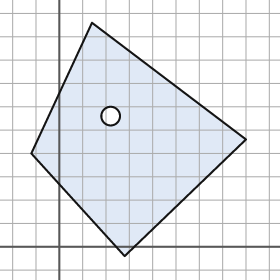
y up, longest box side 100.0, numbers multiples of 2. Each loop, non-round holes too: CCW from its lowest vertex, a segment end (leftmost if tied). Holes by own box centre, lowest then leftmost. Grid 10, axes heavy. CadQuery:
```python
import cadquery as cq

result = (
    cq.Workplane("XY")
    .moveTo(28.0, -4.0)
    .lineTo(80.0, 46.0)
    .lineTo(14.0, 96.0)
    .lineTo(-12.0, 40.0)
    .close()
    .moveTo(22.0, 56.0)
    .circle(4.0)
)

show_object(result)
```